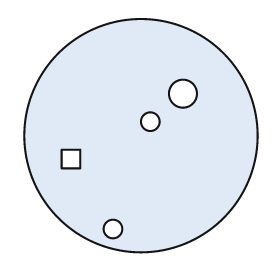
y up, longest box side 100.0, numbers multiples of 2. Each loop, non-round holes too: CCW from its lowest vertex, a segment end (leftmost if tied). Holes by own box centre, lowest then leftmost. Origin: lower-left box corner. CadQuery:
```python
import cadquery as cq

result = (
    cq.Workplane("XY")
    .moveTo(50.0, 50.0)
    .circle(50.0)
    .moveTo(38.0, 10.0)
    .circle(4.0)
    .moveTo(16.0, 36.0)
    .lineTo(24.0, 36.0)
    .lineTo(24.0, 44.0)
    .lineTo(16.0, 44.0)
    .close()
    .moveTo(54.0, 56.0)
    .circle(4.0)
    .moveTo(68.0, 68.0)
    .circle(6.0)
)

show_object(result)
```